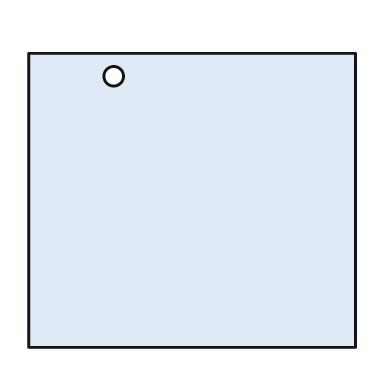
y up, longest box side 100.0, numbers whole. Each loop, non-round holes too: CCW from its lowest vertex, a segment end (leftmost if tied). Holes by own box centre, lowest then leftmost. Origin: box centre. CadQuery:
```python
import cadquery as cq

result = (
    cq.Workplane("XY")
    .moveTo(-50.0, -45.0)
    .lineTo(50.0, -45.0)
    .lineTo(50.0, 45.0)
    .lineTo(-50.0, 45.0)
    .close()
    .moveTo(-24.0, 38.0)
    .circle(3.0)
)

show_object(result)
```